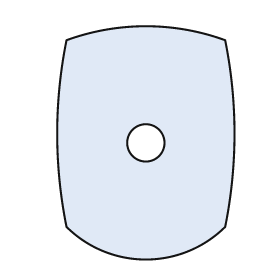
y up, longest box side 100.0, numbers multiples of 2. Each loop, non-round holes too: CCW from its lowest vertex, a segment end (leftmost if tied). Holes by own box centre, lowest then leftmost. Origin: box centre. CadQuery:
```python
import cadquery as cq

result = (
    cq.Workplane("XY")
    .moveTo(-34.0, -36.0)
    .threePointArc((0.0, -50.0), (34.0, -36.0))
    .threePointArc((38.0, 4.0), (34.0, 44.0))
    .threePointArc((0.0, 50.0), (-34.0, 44.0))
    .threePointArc((-38.0, 4.0), (-34.0, -36.0))
    .close()
    .moveTo(0.0, 0.0)
    .circle(8.0)
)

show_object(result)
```